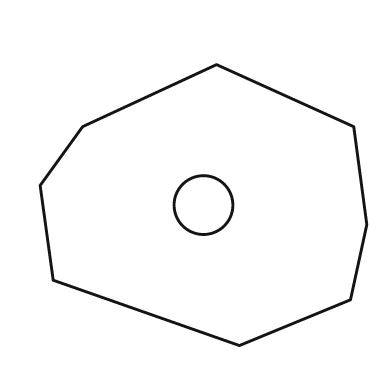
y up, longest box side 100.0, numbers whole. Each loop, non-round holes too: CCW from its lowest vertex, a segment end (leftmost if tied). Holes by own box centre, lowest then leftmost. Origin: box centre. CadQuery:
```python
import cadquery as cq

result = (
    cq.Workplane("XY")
    .moveTo(11.0, -43.0)
    .lineTo(45.0, -29.0)
    .lineTo(50.0, -6.0)
    .lineTo(46.0, 24.0)
    .lineTo(4.0, 43.0)
    .lineTo(-37.0, 24.0)
    .lineTo(-50.0, 6.0)
    .lineTo(-46.0, -23.0)
    .close()
    .moveTo(0.0, 0.0)
    .circle(9.0)
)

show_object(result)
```